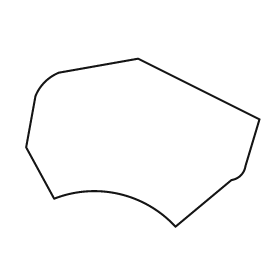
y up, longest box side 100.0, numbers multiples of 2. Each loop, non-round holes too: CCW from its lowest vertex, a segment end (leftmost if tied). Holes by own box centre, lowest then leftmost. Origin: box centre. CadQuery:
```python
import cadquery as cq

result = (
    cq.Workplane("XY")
    .moveTo(14.0, -36.0)
    .lineTo(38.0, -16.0)
    .threePointArc((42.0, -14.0), (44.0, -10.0))
    .lineTo(50.0, 10.0)
    .lineTo(-2.0, 36.0)
    .lineTo(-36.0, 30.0)
    .threePointArc((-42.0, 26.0), (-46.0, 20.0))
    .lineTo(-50.0, -2.0)
    .lineTo(-38.0, -24.0)
    .threePointArc((-10.0, -22.0), (14.0, -36.0))
    .close()
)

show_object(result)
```